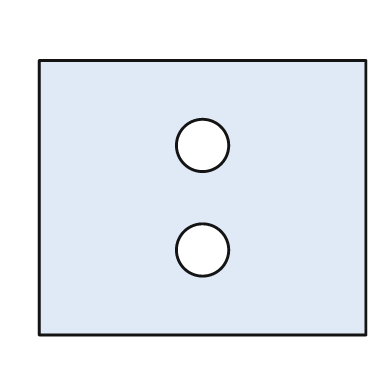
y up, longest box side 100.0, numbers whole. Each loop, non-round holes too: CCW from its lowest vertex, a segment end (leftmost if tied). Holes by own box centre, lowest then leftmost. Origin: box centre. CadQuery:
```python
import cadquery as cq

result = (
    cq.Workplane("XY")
    .moveTo(-50.0, -42.0)
    .lineTo(50.0, -42.0)
    .lineTo(50.0, 42.0)
    .lineTo(-50.0, 42.0)
    .close()
    .moveTo(0.0, -16.0)
    .circle(8.0)
    .moveTo(0.0, 16.0)
    .circle(8.0)
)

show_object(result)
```